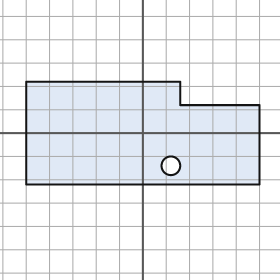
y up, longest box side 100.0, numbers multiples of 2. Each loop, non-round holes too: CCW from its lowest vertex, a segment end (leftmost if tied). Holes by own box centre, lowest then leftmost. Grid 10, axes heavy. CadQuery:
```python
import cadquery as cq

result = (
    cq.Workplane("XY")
    .moveTo(-50.0, -22.0)
    .lineTo(50.0, -22.0)
    .lineTo(50.0, 12.0)
    .lineTo(16.0, 12.0)
    .lineTo(16.0, 22.0)
    .lineTo(-50.0, 22.0)
    .close()
    .moveTo(12.0, -14.0)
    .circle(4.0)
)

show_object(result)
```